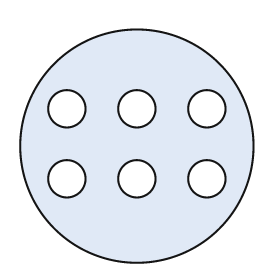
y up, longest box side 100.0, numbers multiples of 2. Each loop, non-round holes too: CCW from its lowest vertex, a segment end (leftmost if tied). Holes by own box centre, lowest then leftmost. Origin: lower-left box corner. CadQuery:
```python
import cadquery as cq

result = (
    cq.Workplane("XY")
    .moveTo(50.0, 50.0)
    .circle(50.0)
    .moveTo(20.0, 36.0)
    .circle(8.0)
    .moveTo(50.0, 36.0)
    .circle(8.0)
    .moveTo(80.0, 36.0)
    .circle(8.0)
    .moveTo(20.0, 66.0)
    .circle(8.0)
    .moveTo(50.0, 66.0)
    .circle(8.0)
    .moveTo(80.0, 66.0)
    .circle(8.0)
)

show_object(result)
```